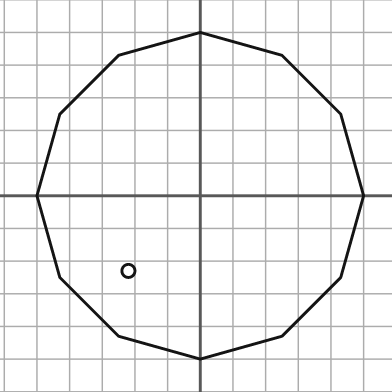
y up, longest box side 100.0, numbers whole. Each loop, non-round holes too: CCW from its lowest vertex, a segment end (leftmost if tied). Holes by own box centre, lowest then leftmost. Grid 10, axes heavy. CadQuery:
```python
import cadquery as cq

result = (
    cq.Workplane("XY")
    .moveTo(0.0, -50.0)
    .lineTo(25.0, -43.0)
    .lineTo(43.0, -25.0)
    .lineTo(50.0, 0.0)
    .lineTo(43.0, 25.0)
    .lineTo(25.0, 43.0)
    .lineTo(0.0, 50.0)
    .lineTo(-25.0, 43.0)
    .lineTo(-43.0, 25.0)
    .lineTo(-50.0, 0.0)
    .lineTo(-43.0, -25.0)
    .lineTo(-25.0, -43.0)
    .close()
    .moveTo(-22.0, -23.0)
    .circle(2.0)
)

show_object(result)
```